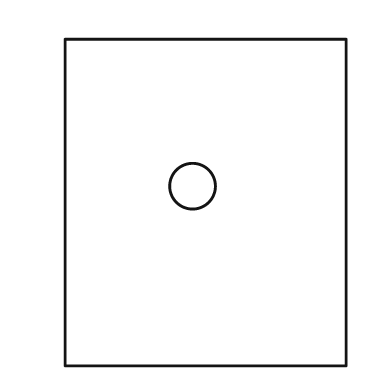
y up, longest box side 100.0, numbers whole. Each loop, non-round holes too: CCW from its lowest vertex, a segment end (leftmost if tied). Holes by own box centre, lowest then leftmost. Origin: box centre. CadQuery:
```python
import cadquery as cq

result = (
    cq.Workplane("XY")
    .moveTo(-43.0, -50.0)
    .lineTo(43.0, -50.0)
    .lineTo(43.0, 50.0)
    .lineTo(-43.0, 50.0)
    .close()
    .moveTo(-4.0, 5.0)
    .circle(7.0)
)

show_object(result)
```